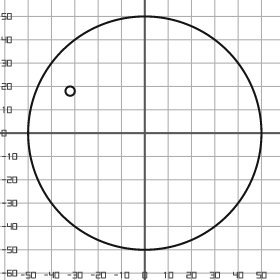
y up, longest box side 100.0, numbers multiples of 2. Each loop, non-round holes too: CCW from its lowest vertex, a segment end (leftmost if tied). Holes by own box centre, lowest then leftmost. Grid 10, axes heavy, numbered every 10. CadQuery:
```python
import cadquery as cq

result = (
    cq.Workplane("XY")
    .moveTo(0.0, 0.0)
    .circle(50.0)
    .moveTo(-32.0, 18.0)
    .circle(2.0)
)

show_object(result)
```